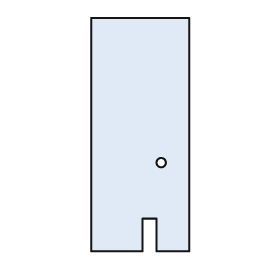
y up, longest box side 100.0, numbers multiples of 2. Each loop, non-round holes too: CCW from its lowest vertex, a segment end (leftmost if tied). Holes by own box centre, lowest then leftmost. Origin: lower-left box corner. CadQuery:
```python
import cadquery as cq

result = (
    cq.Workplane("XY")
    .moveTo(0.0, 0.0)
    .lineTo(22.0, 0.0)
    .lineTo(22.0, 14.0)
    .lineTo(28.0, 14.0)
    .lineTo(28.0, 0.0)
    .lineTo(42.0, 0.0)
    .lineTo(42.0, 100.0)
    .lineTo(0.0, 100.0)
    .close()
    .moveTo(30.0, 38.0)
    .circle(2.0)
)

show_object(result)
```